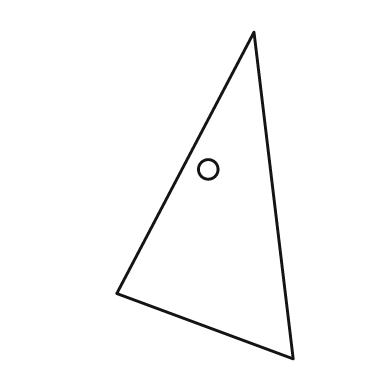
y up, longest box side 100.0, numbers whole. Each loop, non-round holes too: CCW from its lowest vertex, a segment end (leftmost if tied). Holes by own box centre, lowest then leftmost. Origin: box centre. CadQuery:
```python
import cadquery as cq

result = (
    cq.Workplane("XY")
    .moveTo(27.0, -50.0)
    .lineTo(15.0, 50.0)
    .lineTo(-27.0, -30.0)
    .close()
    .moveTo(1.0, 8.0)
    .circle(3.0)
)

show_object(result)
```